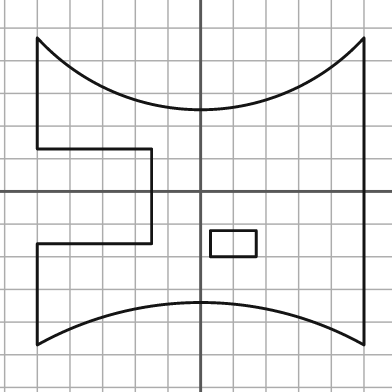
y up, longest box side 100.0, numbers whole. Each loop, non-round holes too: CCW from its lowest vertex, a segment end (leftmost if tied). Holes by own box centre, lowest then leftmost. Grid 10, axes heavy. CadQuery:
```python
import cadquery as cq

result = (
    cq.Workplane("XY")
    .moveTo(-50.0, -47.0)
    .threePointArc((0.0, -34.0), (50.0, -47.0))
    .lineTo(50.0, 47.0)
    .threePointArc((0.0, 25.0), (-50.0, 47.0))
    .lineTo(-50.0, 13.0)
    .lineTo(-15.0, 13.0)
    .lineTo(-15.0, -16.0)
    .lineTo(-50.0, -16.0)
    .close()
    .moveTo(3.0, -20.0)
    .lineTo(17.0, -20.0)
    .lineTo(17.0, -12.0)
    .lineTo(3.0, -12.0)
    .close()
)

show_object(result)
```